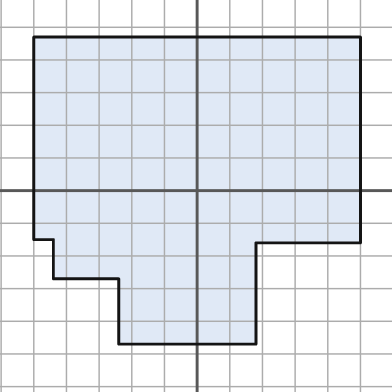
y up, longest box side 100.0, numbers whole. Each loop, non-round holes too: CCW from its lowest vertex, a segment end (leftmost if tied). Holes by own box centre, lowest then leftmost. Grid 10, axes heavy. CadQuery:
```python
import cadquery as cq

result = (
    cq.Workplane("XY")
    .moveTo(-24.0, -47.0)
    .lineTo(18.0, -47.0)
    .lineTo(18.0, -16.0)
    .lineTo(50.0, -16.0)
    .lineTo(50.0, 47.0)
    .lineTo(-50.0, 47.0)
    .lineTo(-50.0, -15.0)
    .lineTo(-44.0, -15.0)
    .lineTo(-44.0, -27.0)
    .lineTo(-24.0, -27.0)
    .close()
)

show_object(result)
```